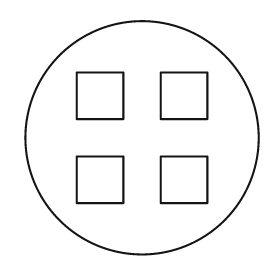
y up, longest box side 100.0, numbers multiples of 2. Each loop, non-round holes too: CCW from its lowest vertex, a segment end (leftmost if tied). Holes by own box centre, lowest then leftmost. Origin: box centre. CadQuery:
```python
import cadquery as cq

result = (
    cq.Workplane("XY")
    .moveTo(0.0, 0.0)
    .circle(50.0)
    .moveTo(-28.0, -28.0)
    .lineTo(-8.0, -28.0)
    .lineTo(-8.0, -8.0)
    .lineTo(-28.0, -8.0)
    .close()
    .moveTo(8.0, -28.0)
    .lineTo(28.0, -28.0)
    .lineTo(28.0, -8.0)
    .lineTo(8.0, -8.0)
    .close()
    .moveTo(-28.0, 8.0)
    .lineTo(-8.0, 8.0)
    .lineTo(-8.0, 28.0)
    .lineTo(-28.0, 28.0)
    .close()
    .moveTo(8.0, 8.0)
    .lineTo(28.0, 8.0)
    .lineTo(28.0, 28.0)
    .lineTo(8.0, 28.0)
    .close()
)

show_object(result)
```